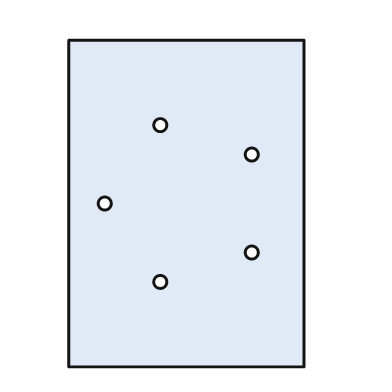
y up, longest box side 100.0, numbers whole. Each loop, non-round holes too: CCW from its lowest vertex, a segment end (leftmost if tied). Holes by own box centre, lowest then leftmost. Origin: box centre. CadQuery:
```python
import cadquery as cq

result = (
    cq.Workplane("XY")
    .moveTo(-36.0, -50.0)
    .lineTo(36.0, -50.0)
    .lineTo(36.0, 50.0)
    .lineTo(-36.0, 50.0)
    .close()
    .moveTo(-8.0, -24.0)
    .circle(2.0)
    .moveTo(20.0, -15.0)
    .circle(2.0)
    .moveTo(-25.0, 0.0)
    .circle(2.0)
    .moveTo(20.0, 15.0)
    .circle(2.0)
    .moveTo(-8.0, 24.0)
    .circle(2.0)
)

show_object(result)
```